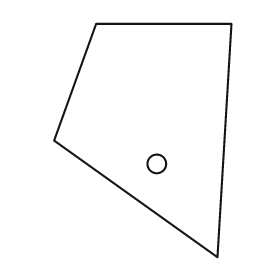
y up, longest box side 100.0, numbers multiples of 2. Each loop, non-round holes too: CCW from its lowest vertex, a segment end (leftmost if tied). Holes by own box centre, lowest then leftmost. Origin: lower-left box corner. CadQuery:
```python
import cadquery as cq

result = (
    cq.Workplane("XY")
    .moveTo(70.0, 0.0)
    .lineTo(76.0, 100.0)
    .lineTo(18.0, 100.0)
    .lineTo(0.0, 50.0)
    .close()
    .moveTo(44.0, 40.0)
    .circle(4.0)
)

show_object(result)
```